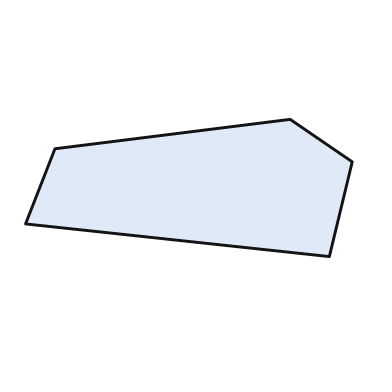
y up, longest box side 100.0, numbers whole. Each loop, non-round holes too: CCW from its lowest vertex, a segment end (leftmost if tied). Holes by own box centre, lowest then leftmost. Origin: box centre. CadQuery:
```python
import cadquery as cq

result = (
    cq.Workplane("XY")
    .moveTo(43.0, -21.0)
    .lineTo(50.0, 8.0)
    .lineTo(31.0, 21.0)
    .lineTo(-41.0, 12.0)
    .lineTo(-50.0, -11.0)
    .close()
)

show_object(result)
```